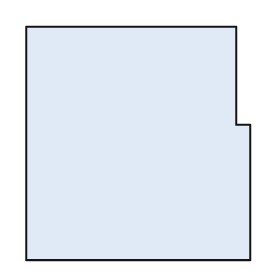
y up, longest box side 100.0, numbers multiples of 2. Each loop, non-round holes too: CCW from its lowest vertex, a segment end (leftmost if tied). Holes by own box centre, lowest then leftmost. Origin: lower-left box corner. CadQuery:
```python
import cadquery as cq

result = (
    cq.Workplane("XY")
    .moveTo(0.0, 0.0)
    .lineTo(96.0, 0.0)
    .lineTo(96.0, 58.0)
    .lineTo(90.0, 58.0)
    .lineTo(90.0, 100.0)
    .lineTo(0.0, 100.0)
    .close()
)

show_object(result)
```